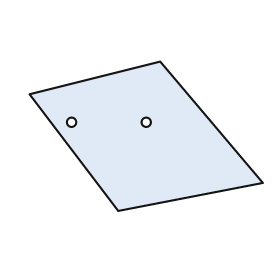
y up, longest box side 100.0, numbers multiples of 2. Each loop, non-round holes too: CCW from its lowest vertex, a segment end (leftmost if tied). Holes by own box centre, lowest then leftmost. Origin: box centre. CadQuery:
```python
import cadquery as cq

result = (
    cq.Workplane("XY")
    .moveTo(-12.0, -32.0)
    .lineTo(50.0, -20.0)
    .lineTo(6.0, 32.0)
    .lineTo(-50.0, 18.0)
    .close()
    .moveTo(-32.0, 6.0)
    .circle(2.0)
    .moveTo(0.0, 6.0)
    .circle(2.0)
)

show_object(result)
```